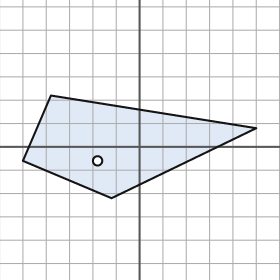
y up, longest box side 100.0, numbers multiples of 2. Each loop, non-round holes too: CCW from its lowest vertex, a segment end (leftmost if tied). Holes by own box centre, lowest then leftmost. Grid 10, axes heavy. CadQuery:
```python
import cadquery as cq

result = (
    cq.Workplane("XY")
    .moveTo(-12.0, -22.0)
    .lineTo(50.0, 8.0)
    .lineTo(-38.0, 22.0)
    .lineTo(-50.0, -6.0)
    .close()
    .moveTo(-18.0, -6.0)
    .circle(2.0)
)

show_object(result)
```